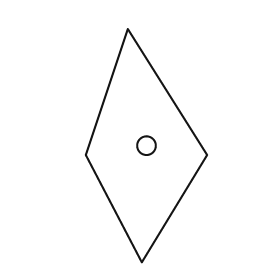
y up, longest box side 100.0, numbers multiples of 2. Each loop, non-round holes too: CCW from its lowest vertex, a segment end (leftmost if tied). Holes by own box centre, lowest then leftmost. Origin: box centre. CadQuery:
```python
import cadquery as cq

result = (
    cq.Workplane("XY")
    .moveTo(-2.0, -50.0)
    .lineTo(26.0, -4.0)
    .lineTo(-8.0, 50.0)
    .lineTo(-26.0, -4.0)
    .close()
    .moveTo(0.0, 0.0)
    .circle(4.0)
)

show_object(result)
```